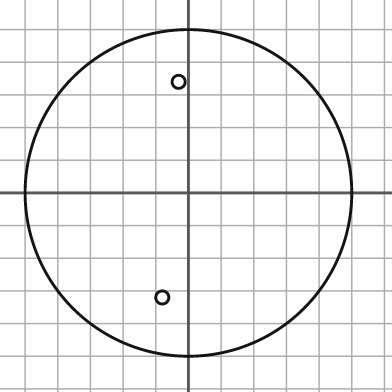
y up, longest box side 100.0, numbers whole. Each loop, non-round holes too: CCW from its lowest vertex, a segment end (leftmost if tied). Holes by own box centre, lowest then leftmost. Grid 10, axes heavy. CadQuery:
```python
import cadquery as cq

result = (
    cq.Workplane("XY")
    .moveTo(0.0, 0.0)
    .circle(50.0)
    .moveTo(-8.0, -32.0)
    .circle(2.0)
    .moveTo(-3.0, 34.0)
    .circle(2.0)
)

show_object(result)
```